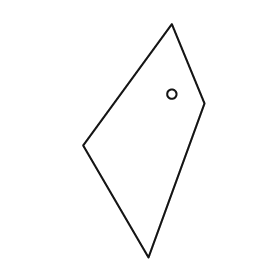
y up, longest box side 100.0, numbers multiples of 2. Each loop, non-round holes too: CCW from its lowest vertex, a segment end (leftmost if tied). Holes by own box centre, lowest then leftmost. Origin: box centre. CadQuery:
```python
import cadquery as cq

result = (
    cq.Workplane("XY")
    .moveTo(2.0, -50.0)
    .lineTo(26.0, 16.0)
    .lineTo(12.0, 50.0)
    .lineTo(-26.0, -2.0)
    .close()
    .moveTo(12.0, 20.0)
    .circle(2.0)
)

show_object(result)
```